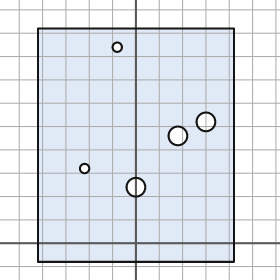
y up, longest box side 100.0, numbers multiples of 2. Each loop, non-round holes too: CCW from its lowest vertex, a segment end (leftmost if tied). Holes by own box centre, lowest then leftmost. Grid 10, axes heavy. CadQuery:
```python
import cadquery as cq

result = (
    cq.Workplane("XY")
    .moveTo(-42.0, -8.0)
    .lineTo(42.0, -8.0)
    .lineTo(42.0, 92.0)
    .lineTo(-42.0, 92.0)
    .close()
    .moveTo(0.0, 24.0)
    .circle(4.0)
    .moveTo(-22.0, 32.0)
    .circle(2.0)
    .moveTo(18.0, 46.0)
    .circle(4.0)
    .moveTo(30.0, 52.0)
    .circle(4.0)
    .moveTo(-8.0, 84.0)
    .circle(2.0)
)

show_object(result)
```